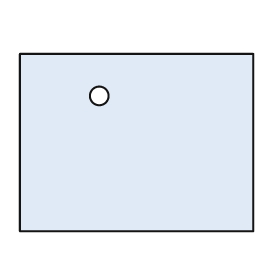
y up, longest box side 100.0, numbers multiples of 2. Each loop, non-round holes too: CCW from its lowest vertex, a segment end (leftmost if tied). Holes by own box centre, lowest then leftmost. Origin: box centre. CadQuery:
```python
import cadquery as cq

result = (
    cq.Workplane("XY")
    .moveTo(-50.0, -38.0)
    .lineTo(50.0, -38.0)
    .lineTo(50.0, 38.0)
    .lineTo(-50.0, 38.0)
    .close()
    .moveTo(-16.0, 20.0)
    .circle(4.0)
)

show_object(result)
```